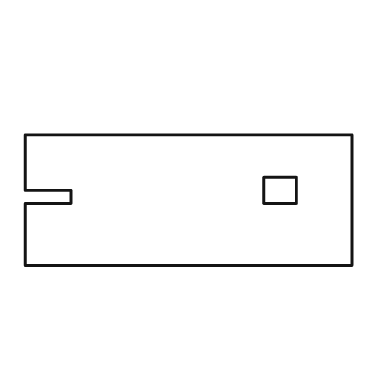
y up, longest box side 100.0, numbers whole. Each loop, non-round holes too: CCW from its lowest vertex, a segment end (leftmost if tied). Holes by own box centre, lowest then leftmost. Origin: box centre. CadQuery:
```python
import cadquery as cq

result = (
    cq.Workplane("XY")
    .moveTo(-50.0, -20.0)
    .lineTo(50.0, -20.0)
    .lineTo(50.0, 20.0)
    .lineTo(-50.0, 20.0)
    .lineTo(-50.0, 3.0)
    .lineTo(-36.0, 3.0)
    .lineTo(-36.0, -1.0)
    .lineTo(-50.0, -1.0)
    .close()
    .moveTo(23.0, -1.0)
    .lineTo(33.0, -1.0)
    .lineTo(33.0, 7.0)
    .lineTo(23.0, 7.0)
    .close()
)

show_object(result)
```